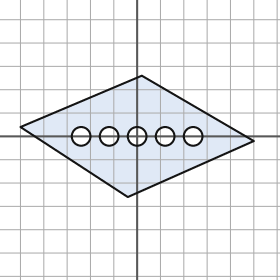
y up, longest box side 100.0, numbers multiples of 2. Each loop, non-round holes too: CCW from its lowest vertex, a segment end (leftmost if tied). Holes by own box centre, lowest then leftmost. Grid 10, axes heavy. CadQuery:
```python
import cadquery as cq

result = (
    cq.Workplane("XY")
    .moveTo(-4.0, -26.0)
    .lineTo(50.0, -2.0)
    .lineTo(2.0, 26.0)
    .lineTo(-50.0, 4.0)
    .close()
    .moveTo(-24.0, 0.0)
    .circle(4.0)
    .moveTo(-12.0, 0.0)
    .circle(4.0)
    .moveTo(0.0, 0.0)
    .circle(4.0)
    .moveTo(12.0, 0.0)
    .circle(4.0)
    .moveTo(24.0, 0.0)
    .circle(4.0)
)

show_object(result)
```